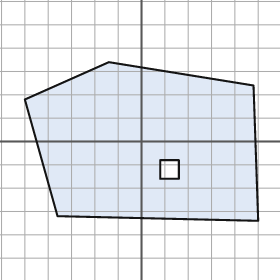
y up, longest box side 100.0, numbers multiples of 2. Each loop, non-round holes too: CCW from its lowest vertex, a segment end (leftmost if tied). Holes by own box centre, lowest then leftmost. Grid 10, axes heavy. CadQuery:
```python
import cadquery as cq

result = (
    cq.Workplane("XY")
    .moveTo(50.0, -34.0)
    .lineTo(48.0, 24.0)
    .lineTo(-14.0, 34.0)
    .lineTo(-50.0, 18.0)
    .lineTo(-36.0, -32.0)
    .close()
    .moveTo(8.0, -16.0)
    .lineTo(16.0, -16.0)
    .lineTo(16.0, -8.0)
    .lineTo(8.0, -8.0)
    .close()
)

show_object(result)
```